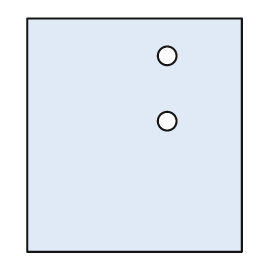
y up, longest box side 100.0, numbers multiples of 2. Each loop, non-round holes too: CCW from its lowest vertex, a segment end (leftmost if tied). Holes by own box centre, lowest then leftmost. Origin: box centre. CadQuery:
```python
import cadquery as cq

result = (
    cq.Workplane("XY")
    .moveTo(-46.0, -50.0)
    .lineTo(46.0, -50.0)
    .lineTo(46.0, 50.0)
    .lineTo(-46.0, 50.0)
    .close()
    .moveTo(14.0, 6.0)
    .circle(4.0)
    .moveTo(14.0, 34.0)
    .circle(4.0)
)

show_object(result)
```